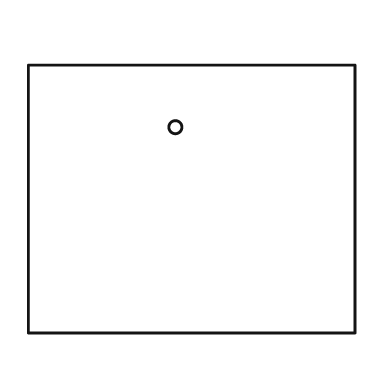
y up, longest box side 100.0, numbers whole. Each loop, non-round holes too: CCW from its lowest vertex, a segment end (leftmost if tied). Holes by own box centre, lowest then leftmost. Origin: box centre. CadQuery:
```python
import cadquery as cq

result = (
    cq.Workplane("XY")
    .moveTo(-50.0, -41.0)
    .lineTo(50.0, -41.0)
    .lineTo(50.0, 41.0)
    .lineTo(-50.0, 41.0)
    .close()
    .moveTo(-5.0, 22.0)
    .circle(2.0)
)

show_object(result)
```